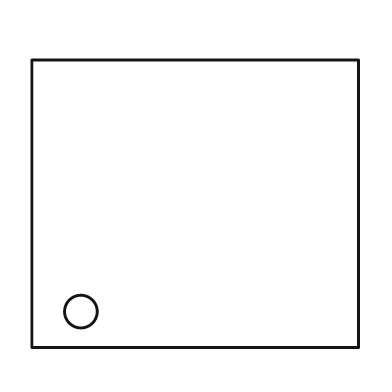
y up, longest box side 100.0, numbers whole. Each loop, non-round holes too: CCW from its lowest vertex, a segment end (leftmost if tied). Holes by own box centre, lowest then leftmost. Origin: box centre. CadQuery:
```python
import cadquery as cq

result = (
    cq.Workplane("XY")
    .moveTo(-50.0, -44.0)
    .lineTo(50.0, -44.0)
    .lineTo(50.0, 44.0)
    .lineTo(-50.0, 44.0)
    .close()
    .moveTo(-35.0, -33.0)
    .circle(5.0)
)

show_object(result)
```